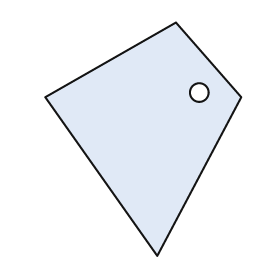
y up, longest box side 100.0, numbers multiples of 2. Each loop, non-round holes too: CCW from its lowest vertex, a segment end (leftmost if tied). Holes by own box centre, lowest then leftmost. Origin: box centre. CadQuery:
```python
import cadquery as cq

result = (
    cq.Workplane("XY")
    .moveTo(6.0, -50.0)
    .lineTo(42.0, 18.0)
    .lineTo(14.0, 50.0)
    .lineTo(-42.0, 18.0)
    .close()
    .moveTo(24.0, 20.0)
    .circle(4.0)
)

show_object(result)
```